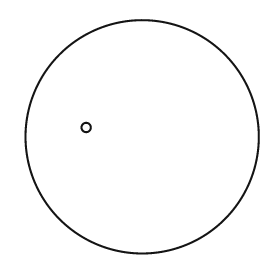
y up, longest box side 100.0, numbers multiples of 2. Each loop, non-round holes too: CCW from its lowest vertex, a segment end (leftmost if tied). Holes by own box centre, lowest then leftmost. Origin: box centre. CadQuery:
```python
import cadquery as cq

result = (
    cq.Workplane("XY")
    .moveTo(0.0, 0.0)
    .circle(50.0)
    .moveTo(-24.0, 4.0)
    .circle(2.0)
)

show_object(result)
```